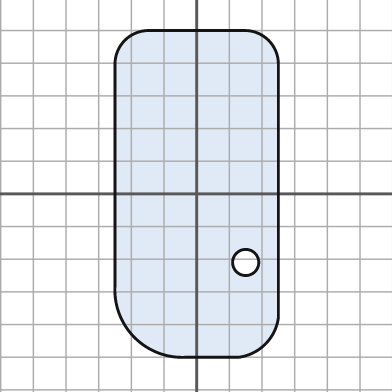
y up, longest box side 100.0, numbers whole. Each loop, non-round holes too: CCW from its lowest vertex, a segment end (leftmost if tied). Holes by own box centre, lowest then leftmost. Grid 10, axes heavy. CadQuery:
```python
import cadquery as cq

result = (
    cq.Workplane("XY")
    .moveTo(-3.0, -50.0)
    .lineTo(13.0, -50.0)
    .threePointArc((21.0, -46.0), (25.0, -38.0))
    .lineTo(25.0, 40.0)
    .threePointArc((22.0, 47.0), (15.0, 50.0))
    .lineTo(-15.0, 50.0)
    .threePointArc((-22.0, 47.0), (-25.0, 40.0))
    .lineTo(-25.0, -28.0)
    .threePointArc((-19.0, -44.0), (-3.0, -50.0))
    .close()
    .moveTo(15.0, -21.0)
    .circle(4.0)
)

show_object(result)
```